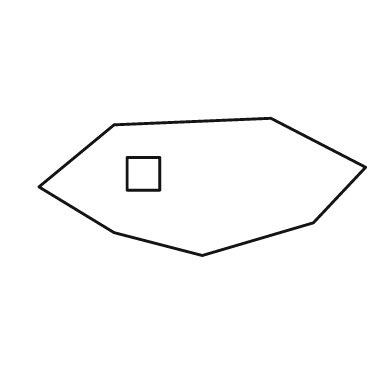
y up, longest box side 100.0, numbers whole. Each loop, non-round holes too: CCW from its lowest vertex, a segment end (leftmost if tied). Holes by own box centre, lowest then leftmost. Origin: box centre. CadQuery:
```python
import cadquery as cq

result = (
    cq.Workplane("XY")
    .moveTo(0.0, -21.0)
    .lineTo(34.0, -11.0)
    .lineTo(50.0, 6.0)
    .lineTo(21.0, 21.0)
    .lineTo(-27.0, 19.0)
    .lineTo(-50.0, 0.0)
    .lineTo(-27.0, -14.0)
    .close()
    .moveTo(-23.0, -1.0)
    .lineTo(-13.0, -1.0)
    .lineTo(-13.0, 9.0)
    .lineTo(-23.0, 9.0)
    .close()
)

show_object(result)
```